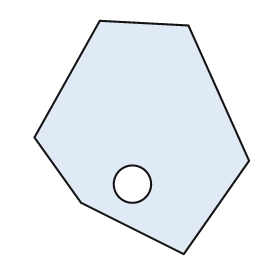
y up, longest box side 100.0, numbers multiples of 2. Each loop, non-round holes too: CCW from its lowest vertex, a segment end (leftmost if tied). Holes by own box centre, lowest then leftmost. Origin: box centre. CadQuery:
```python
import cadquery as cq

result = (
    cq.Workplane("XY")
    .moveTo(18.0, -50.0)
    .lineTo(46.0, -10.0)
    .lineTo(20.0, 48.0)
    .lineTo(-18.0, 50.0)
    .lineTo(-46.0, 0.0)
    .lineTo(-26.0, -28.0)
    .close()
    .moveTo(-4.0, -20.0)
    .circle(8.0)
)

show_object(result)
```